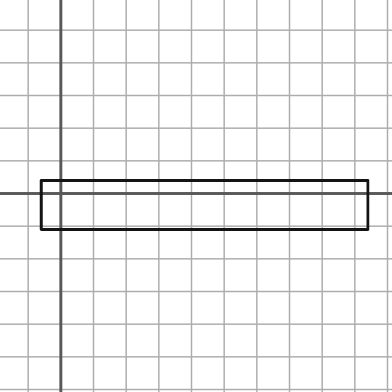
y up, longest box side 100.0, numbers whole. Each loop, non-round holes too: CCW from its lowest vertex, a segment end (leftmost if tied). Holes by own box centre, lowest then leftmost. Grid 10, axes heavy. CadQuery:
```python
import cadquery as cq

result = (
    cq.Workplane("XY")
    .moveTo(-6.0, -11.0)
    .lineTo(94.0, -11.0)
    .lineTo(94.0, 4.0)
    .lineTo(-6.0, 4.0)
    .close()
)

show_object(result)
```